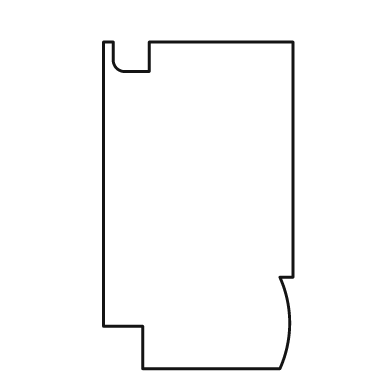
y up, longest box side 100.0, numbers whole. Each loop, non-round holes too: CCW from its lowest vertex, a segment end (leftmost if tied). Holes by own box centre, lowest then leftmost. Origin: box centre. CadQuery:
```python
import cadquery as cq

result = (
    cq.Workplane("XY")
    .moveTo(-17.0, -50.0)
    .lineTo(25.0, -50.0)
    .threePointArc((28.0, -36.0), (25.0, -22.0))
    .lineTo(29.0, -22.0)
    .lineTo(29.0, 50.0)
    .lineTo(-15.0, 50.0)
    .lineTo(-15.0, 41.0)
    .lineTo(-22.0, 41.0)
    .threePointArc((-25.0, 42.0), (-26.0, 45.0))
    .lineTo(-26.0, 50.0)
    .lineTo(-29.0, 50.0)
    .lineTo(-29.0, -37.0)
    .lineTo(-17.0, -37.0)
    .close()
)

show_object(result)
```